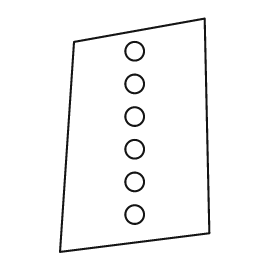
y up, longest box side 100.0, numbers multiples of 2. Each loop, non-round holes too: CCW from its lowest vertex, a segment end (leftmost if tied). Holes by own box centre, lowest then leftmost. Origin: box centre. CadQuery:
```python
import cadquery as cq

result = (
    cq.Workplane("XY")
    .moveTo(-32.0, -50.0)
    .lineTo(32.0, -42.0)
    .lineTo(30.0, 50.0)
    .lineTo(-26.0, 40.0)
    .close()
    .moveTo(0.0, -34.0)
    .circle(4.0)
    .moveTo(0.0, -20.0)
    .circle(4.0)
    .moveTo(0.0, -6.0)
    .circle(4.0)
    .moveTo(0.0, 8.0)
    .circle(4.0)
    .moveTo(0.0, 22.0)
    .circle(4.0)
    .moveTo(0.0, 36.0)
    .circle(4.0)
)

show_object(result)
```